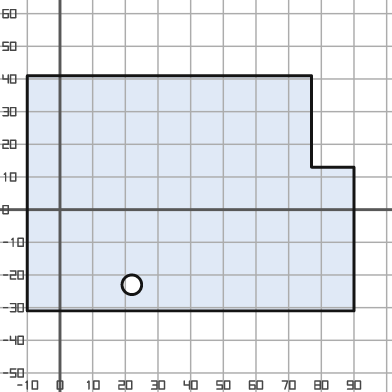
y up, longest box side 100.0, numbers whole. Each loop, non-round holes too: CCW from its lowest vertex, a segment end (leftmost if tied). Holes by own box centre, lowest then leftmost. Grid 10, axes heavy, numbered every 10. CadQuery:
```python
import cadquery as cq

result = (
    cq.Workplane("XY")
    .moveTo(-10.0, -31.0)
    .lineTo(90.0, -31.0)
    .lineTo(90.0, 13.0)
    .lineTo(77.0, 13.0)
    .lineTo(77.0, 41.0)
    .lineTo(-10.0, 41.0)
    .close()
    .moveTo(22.0, -23.0)
    .circle(3.0)
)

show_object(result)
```